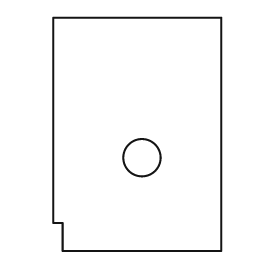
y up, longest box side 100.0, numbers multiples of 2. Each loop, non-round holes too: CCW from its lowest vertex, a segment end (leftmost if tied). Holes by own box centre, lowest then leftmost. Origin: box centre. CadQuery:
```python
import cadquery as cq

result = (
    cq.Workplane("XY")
    .moveTo(-32.0, -50.0)
    .lineTo(36.0, -50.0)
    .lineTo(36.0, 50.0)
    .lineTo(-36.0, 50.0)
    .lineTo(-36.0, -38.0)
    .lineTo(-32.0, -38.0)
    .close()
    .moveTo(2.0, -10.0)
    .circle(8.0)
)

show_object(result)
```